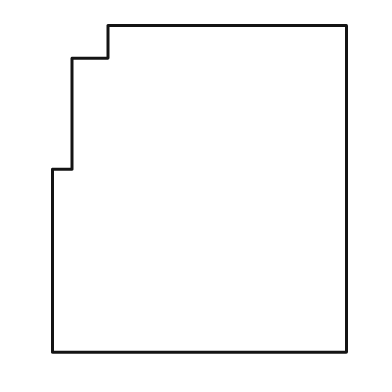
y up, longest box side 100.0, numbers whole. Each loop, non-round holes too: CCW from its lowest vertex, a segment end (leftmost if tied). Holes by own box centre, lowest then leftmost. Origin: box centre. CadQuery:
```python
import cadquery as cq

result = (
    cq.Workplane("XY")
    .moveTo(-45.0, -50.0)
    .lineTo(45.0, -50.0)
    .lineTo(45.0, 50.0)
    .lineTo(-28.0, 50.0)
    .lineTo(-28.0, 40.0)
    .lineTo(-39.0, 40.0)
    .lineTo(-39.0, 6.0)
    .lineTo(-45.0, 6.0)
    .close()
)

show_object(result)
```